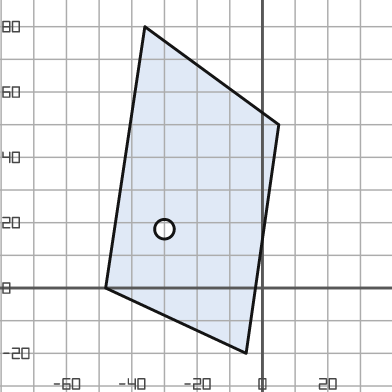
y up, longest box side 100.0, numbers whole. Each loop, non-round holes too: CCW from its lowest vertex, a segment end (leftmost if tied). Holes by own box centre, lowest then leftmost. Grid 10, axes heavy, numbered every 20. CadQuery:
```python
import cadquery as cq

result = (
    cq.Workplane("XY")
    .moveTo(-5.0, -20.0)
    .lineTo(5.0, 50.0)
    .lineTo(-36.0, 80.0)
    .lineTo(-48.0, 0.0)
    .close()
    .moveTo(-30.0, 18.0)
    .circle(3.0)
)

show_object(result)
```